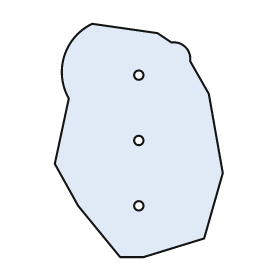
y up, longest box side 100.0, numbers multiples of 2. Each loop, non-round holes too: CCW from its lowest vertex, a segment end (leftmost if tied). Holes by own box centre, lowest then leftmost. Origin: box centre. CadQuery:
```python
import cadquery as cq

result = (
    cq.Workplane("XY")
    .moveTo(-8.0, -50.0)
    .lineTo(2.0, -50.0)
    .lineTo(28.0, -42.0)
    .lineTo(36.0, -14.0)
    .lineTo(30.0, 20.0)
    .lineTo(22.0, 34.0)
    .threePointArc((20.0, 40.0), (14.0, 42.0))
    .lineTo(8.0, 46.0)
    .lineTo(-20.0, 50.0)
    .threePointArc((-32.0, 36.0), (-30.0, 18.0))
    .lineTo(-36.0, -10.0)
    .lineTo(-26.0, -28.0)
    .close()
    .moveTo(0.0, -28.0)
    .circle(2.0)
    .moveTo(0.0, 0.0)
    .circle(2.0)
    .moveTo(0.0, 28.0)
    .circle(2.0)
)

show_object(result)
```